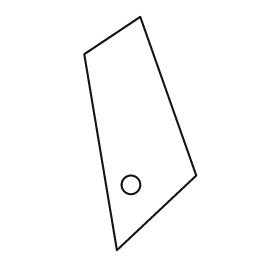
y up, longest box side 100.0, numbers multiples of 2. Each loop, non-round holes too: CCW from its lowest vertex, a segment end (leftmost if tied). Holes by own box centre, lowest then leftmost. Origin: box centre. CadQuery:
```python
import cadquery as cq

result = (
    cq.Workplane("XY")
    .moveTo(-10.0, -50.0)
    .lineTo(24.0, -18.0)
    .lineTo(0.0, 50.0)
    .lineTo(-24.0, 34.0)
    .close()
    .moveTo(-4.0, -22.0)
    .circle(4.0)
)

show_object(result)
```